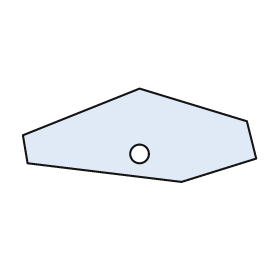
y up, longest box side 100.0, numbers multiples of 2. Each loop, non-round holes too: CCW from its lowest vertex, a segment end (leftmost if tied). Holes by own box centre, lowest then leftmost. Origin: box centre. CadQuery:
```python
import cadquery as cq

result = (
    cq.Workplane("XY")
    .moveTo(18.0, -20.0)
    .lineTo(50.0, -10.0)
    .lineTo(46.0, 6.0)
    .lineTo(0.0, 20.0)
    .lineTo(-50.0, 0.0)
    .lineTo(-48.0, -12.0)
    .close()
    .moveTo(0.0, -8.0)
    .circle(4.0)
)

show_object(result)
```